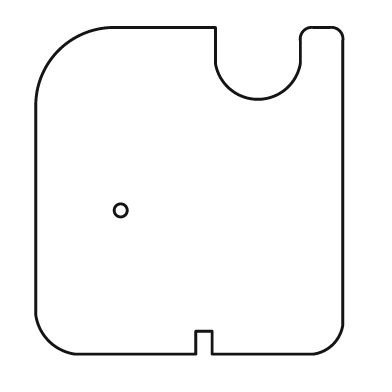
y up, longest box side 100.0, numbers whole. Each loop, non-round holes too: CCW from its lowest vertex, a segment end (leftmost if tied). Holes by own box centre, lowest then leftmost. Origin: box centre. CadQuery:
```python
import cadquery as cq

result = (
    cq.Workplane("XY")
    .moveTo(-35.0, -50.0)
    .lineTo(2.0, -50.0)
    .lineTo(2.0, -43.0)
    .lineTo(7.0, -43.0)
    .lineTo(7.0, -50.0)
    .lineTo(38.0, -50.0)
    .threePointArc((44.0, -47.0), (47.0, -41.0))
    .lineTo(47.0, 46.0)
    .threePointArc((46.0, 49.0), (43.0, 50.0))
    .lineTo(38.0, 50.0)
    .threePointArc((35.0, 49.0), (34.0, 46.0))
    .lineTo(34.0, 39.0)
    .threePointArc((21.0, 28.0), (8.0, 39.0))
    .lineTo(8.0, 50.0)
    .lineTo(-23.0, 50.0)
    .threePointArc((-40.0, 43.0), (-47.0, 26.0))
    .lineTo(-47.0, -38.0)
    .threePointArc((-43.0, -46.0), (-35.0, -50.0))
    .close()
    .moveTo(-21.0, -6.0)
    .circle(2.0)
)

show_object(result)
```